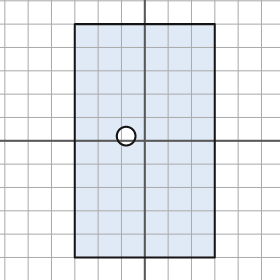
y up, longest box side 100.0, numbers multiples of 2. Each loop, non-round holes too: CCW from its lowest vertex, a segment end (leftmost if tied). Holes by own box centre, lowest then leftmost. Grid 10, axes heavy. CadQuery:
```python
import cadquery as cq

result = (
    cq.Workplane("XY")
    .moveTo(-30.0, -50.0)
    .lineTo(30.0, -50.0)
    .lineTo(30.0, 50.0)
    .lineTo(-30.0, 50.0)
    .close()
    .moveTo(-8.0, 2.0)
    .circle(4.0)
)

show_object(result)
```